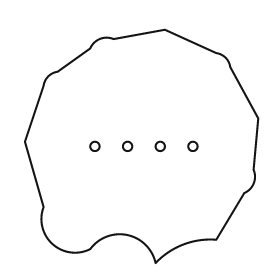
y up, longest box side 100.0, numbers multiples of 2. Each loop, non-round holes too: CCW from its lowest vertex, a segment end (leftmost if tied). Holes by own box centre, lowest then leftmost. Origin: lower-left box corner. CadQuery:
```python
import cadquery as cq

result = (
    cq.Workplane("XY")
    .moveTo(56.0, 0.0)
    .threePointArc((68.0, 8.0), (82.0, 10.0))
    .lineTo(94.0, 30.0)
    .threePointArc((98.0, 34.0), (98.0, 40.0))
    .lineTo(100.0, 62.0)
    .lineTo(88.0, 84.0)
    .threePointArc((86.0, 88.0), (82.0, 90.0))
    .lineTo(60.0, 100.0)
    .lineTo(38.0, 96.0)
    .threePointArc((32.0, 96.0), (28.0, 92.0))
    .lineTo(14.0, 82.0)
    .threePointArc((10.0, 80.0), (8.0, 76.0))
    .lineTo(0.0, 52.0)
    .lineTo(8.0, 24.0)
    .threePointArc((12.0, 8.0), (28.0, 6.0))
    .threePointArc((44.0, 12.0), (56.0, 0.0))
    .close()
    .moveTo(30.0, 50.0)
    .circle(2.0)
    .moveTo(44.0, 50.0)
    .circle(2.0)
    .moveTo(58.0, 50.0)
    .circle(2.0)
    .moveTo(72.0, 50.0)
    .circle(2.0)
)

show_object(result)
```